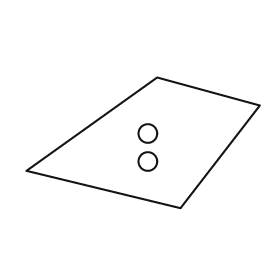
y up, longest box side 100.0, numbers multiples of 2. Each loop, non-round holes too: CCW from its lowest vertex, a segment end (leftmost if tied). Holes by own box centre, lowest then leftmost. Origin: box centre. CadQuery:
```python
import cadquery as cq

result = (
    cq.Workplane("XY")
    .moveTo(16.0, -28.0)
    .lineTo(50.0, 16.0)
    .lineTo(6.0, 28.0)
    .lineTo(-50.0, -12.0)
    .close()
    .moveTo(2.0, -8.0)
    .circle(4.0)
    .moveTo(2.0, 4.0)
    .circle(4.0)
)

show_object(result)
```